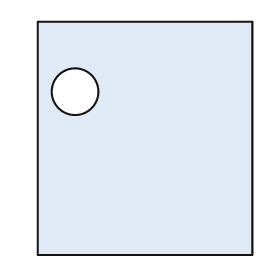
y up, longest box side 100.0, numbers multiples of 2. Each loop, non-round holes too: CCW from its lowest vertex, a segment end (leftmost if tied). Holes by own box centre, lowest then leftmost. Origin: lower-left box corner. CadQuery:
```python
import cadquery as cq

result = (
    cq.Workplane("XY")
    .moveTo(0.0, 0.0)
    .lineTo(92.0, 0.0)
    .lineTo(92.0, 100.0)
    .lineTo(0.0, 100.0)
    .close()
    .moveTo(16.0, 70.0)
    .circle(10.0)
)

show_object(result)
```